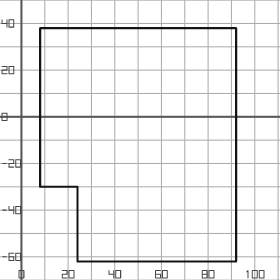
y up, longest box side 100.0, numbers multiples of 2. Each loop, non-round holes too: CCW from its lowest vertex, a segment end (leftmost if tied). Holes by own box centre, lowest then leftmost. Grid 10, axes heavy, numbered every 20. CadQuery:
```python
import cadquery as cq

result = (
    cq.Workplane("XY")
    .moveTo(24.0, -62.0)
    .lineTo(92.0, -62.0)
    .lineTo(92.0, 38.0)
    .lineTo(8.0, 38.0)
    .lineTo(8.0, -30.0)
    .lineTo(24.0, -30.0)
    .close()
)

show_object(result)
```